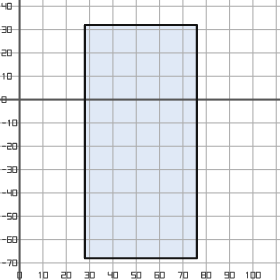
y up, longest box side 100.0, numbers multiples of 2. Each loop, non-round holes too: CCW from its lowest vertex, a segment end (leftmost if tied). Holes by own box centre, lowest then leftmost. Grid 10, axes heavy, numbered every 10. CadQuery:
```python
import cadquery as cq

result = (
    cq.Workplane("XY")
    .moveTo(28.0, -68.0)
    .lineTo(76.0, -68.0)
    .lineTo(76.0, 32.0)
    .lineTo(28.0, 32.0)
    .close()
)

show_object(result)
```